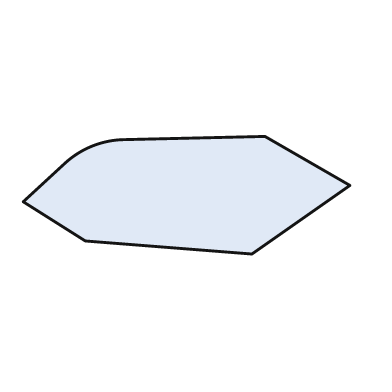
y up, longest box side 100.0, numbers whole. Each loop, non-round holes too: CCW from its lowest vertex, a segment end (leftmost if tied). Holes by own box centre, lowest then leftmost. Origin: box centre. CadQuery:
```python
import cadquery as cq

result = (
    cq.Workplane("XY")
    .moveTo(20.0, -18.0)
    .lineTo(50.0, 3.0)
    .lineTo(24.0, 18.0)
    .lineTo(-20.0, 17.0)
    .threePointArc((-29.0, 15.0), (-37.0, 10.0))
    .lineTo(-50.0, -2.0)
    .lineTo(-31.0, -14.0)
    .close()
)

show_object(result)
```